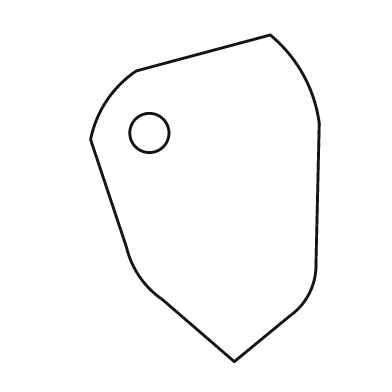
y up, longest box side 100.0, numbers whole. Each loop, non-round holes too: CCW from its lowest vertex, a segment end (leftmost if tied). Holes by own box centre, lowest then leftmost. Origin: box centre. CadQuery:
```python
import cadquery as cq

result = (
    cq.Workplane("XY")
    .moveTo(9.0, -50.0)
    .lineTo(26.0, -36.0)
    .threePointArc((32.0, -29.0), (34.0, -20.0))
    .lineTo(35.0, 23.0)
    .threePointArc((30.0, 38.0), (20.0, 50.0))
    .lineTo(-21.0, 39.0)
    .threePointArc((-30.0, 30.0), (-35.0, 18.0))
    .lineTo(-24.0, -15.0)
    .threePointArc((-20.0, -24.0), (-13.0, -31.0))
    .close()
    .moveTo(-17.0, 20.0)
    .circle(6.0)
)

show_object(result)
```